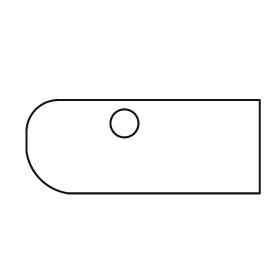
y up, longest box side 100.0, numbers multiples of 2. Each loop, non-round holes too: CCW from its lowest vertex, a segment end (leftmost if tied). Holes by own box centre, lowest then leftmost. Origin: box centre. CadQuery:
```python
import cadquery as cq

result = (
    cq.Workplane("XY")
    .moveTo(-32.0, -20.0)
    .lineTo(50.0, -20.0)
    .lineTo(50.0, 20.0)
    .lineTo(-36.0, 20.0)
    .threePointArc((-46.0, 16.0), (-50.0, 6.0))
    .lineTo(-50.0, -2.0)
    .threePointArc((-44.0, -14.0), (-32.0, -20.0))
    .close()
    .moveTo(-8.0, 10.0)
    .circle(6.0)
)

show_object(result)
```